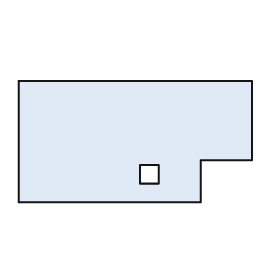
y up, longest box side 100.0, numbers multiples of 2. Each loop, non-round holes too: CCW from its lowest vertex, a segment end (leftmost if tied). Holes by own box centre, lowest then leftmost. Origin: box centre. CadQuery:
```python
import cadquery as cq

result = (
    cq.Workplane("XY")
    .moveTo(-50.0, -26.0)
    .lineTo(28.0, -26.0)
    .lineTo(28.0, -8.0)
    .lineTo(50.0, -8.0)
    .lineTo(50.0, 26.0)
    .lineTo(-50.0, 26.0)
    .close()
    .moveTo(2.0, -18.0)
    .lineTo(10.0, -18.0)
    .lineTo(10.0, -10.0)
    .lineTo(2.0, -10.0)
    .close()
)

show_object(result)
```